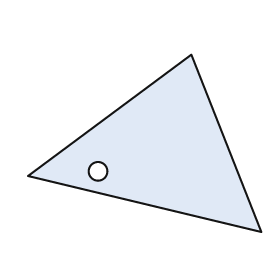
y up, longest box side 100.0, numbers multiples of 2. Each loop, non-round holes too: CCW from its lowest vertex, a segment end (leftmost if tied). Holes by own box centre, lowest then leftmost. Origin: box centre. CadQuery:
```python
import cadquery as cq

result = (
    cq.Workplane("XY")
    .moveTo(50.0, -38.0)
    .lineTo(20.0, 38.0)
    .lineTo(-50.0, -14.0)
    .close()
    .moveTo(-20.0, -12.0)
    .circle(4.0)
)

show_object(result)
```